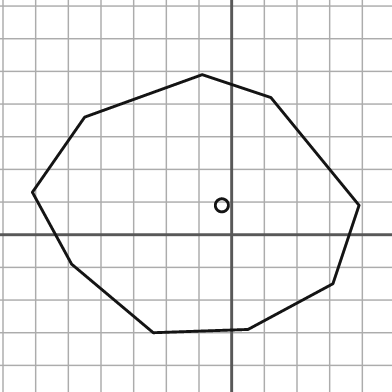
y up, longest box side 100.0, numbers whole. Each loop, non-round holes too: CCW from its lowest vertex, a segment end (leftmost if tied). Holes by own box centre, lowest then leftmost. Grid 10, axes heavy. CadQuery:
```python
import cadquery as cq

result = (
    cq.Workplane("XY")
    .moveTo(-24.0, -30.0)
    .lineTo(5.0, -29.0)
    .lineTo(31.0, -15.0)
    .lineTo(39.0, 9.0)
    .lineTo(12.0, 42.0)
    .lineTo(-9.0, 49.0)
    .lineTo(-45.0, 36.0)
    .lineTo(-61.0, 13.0)
    .lineTo(-49.0, -9.0)
    .close()
    .moveTo(-3.0, 9.0)
    .circle(2.0)
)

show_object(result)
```